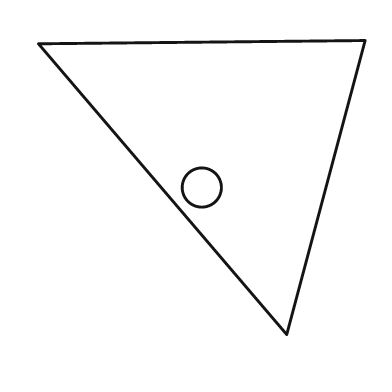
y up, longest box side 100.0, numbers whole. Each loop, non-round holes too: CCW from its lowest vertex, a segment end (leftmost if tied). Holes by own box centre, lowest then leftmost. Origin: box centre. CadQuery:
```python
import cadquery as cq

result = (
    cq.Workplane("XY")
    .moveTo(26.0, -45.0)
    .lineTo(50.0, 45.0)
    .lineTo(-50.0, 44.0)
    .close()
    .moveTo(0.0, 0.0)
    .circle(6.0)
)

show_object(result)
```